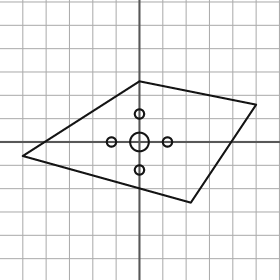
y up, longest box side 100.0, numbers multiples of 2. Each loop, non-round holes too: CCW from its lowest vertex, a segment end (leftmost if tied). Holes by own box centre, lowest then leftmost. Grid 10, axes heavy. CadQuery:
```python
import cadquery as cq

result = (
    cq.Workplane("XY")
    .moveTo(22.0, -26.0)
    .lineTo(50.0, 16.0)
    .lineTo(0.0, 26.0)
    .lineTo(-50.0, -6.0)
    .close()
    .moveTo(0.0, -12.0)
    .circle(2.0)
    .moveTo(-12.0, 0.0)
    .circle(2.0)
    .moveTo(0.0, 0.0)
    .circle(4.0)
    .moveTo(12.0, 0.0)
    .circle(2.0)
    .moveTo(0.0, 12.0)
    .circle(2.0)
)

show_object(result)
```